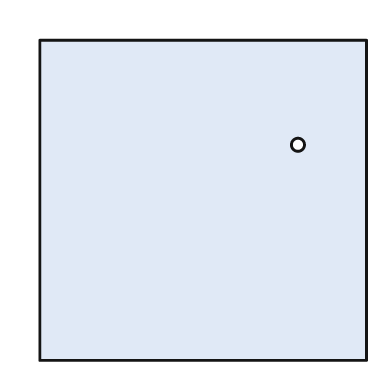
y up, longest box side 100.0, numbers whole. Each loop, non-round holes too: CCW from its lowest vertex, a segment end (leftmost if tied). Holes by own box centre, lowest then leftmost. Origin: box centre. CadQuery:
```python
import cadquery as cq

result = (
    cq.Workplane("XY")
    .moveTo(-50.0, -49.0)
    .lineTo(50.0, -49.0)
    .lineTo(50.0, 49.0)
    .lineTo(-50.0, 49.0)
    .close()
    .moveTo(29.0, 17.0)
    .circle(2.0)
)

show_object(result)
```